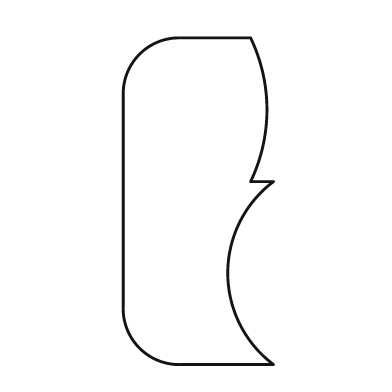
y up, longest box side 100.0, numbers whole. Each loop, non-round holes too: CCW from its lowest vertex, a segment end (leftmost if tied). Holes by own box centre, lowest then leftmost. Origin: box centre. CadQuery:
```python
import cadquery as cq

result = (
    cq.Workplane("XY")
    .moveTo(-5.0, -50.0)
    .lineTo(23.0, -50.0)
    .threePointArc((9.0, -22.0), (23.0, 6.0))
    .lineTo(16.0, 6.0)
    .threePointArc((21.0, 28.0), (16.0, 50.0))
    .lineTo(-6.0, 50.0)
    .threePointArc((-18.0, 45.0), (-23.0, 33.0))
    .lineTo(-23.0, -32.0)
    .threePointArc((-18.0, -45.0), (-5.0, -50.0))
    .close()
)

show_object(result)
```